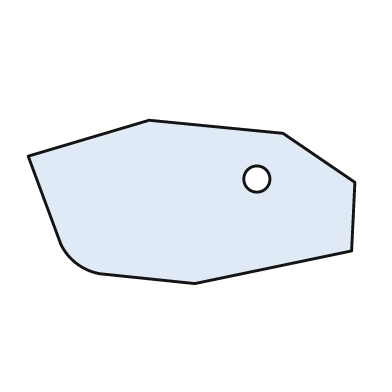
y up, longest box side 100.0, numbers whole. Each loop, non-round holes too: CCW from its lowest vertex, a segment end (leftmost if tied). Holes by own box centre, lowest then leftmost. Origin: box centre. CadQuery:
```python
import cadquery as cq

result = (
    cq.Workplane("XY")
    .moveTo(1.0, -25.0)
    .lineTo(49.0, -15.0)
    .lineTo(50.0, 6.0)
    .lineTo(28.0, 21.0)
    .lineTo(-13.0, 25.0)
    .lineTo(-50.0, 14.0)
    .lineTo(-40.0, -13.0)
    .threePointArc((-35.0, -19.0), (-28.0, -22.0))
    .close()
    .moveTo(20.0, 7.0)
    .circle(4.0)
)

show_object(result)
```